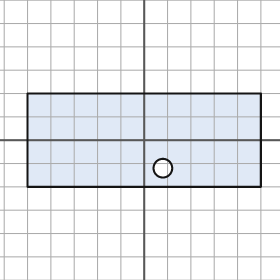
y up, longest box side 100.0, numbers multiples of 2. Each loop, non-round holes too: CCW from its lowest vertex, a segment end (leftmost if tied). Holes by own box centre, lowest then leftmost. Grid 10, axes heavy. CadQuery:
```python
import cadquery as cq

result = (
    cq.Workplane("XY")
    .moveTo(-50.0, -20.0)
    .lineTo(50.0, -20.0)
    .lineTo(50.0, 20.0)
    .lineTo(-50.0, 20.0)
    .close()
    .moveTo(8.0, -12.0)
    .circle(4.0)
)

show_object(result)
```